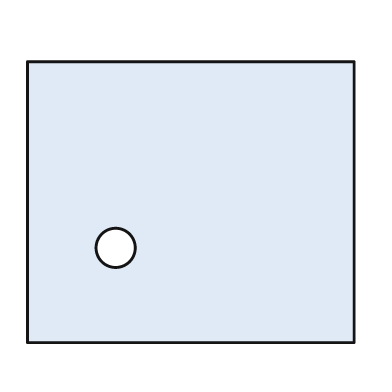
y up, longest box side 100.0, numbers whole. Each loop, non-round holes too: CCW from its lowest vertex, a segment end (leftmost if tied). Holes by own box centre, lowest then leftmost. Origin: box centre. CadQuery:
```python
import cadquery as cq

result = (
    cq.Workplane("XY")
    .moveTo(-50.0, -43.0)
    .lineTo(50.0, -43.0)
    .lineTo(50.0, 43.0)
    .lineTo(-50.0, 43.0)
    .close()
    .moveTo(-23.0, -14.0)
    .circle(6.0)
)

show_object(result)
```